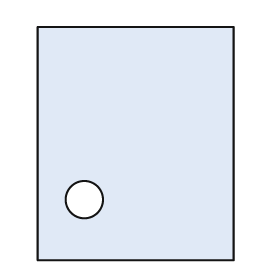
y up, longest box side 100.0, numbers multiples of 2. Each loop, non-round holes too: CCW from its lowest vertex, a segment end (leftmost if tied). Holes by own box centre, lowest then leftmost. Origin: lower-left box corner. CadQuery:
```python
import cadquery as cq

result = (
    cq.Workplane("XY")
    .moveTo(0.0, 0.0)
    .lineTo(84.0, 0.0)
    .lineTo(84.0, 100.0)
    .lineTo(0.0, 100.0)
    .close()
    .moveTo(20.0, 26.0)
    .circle(8.0)
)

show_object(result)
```